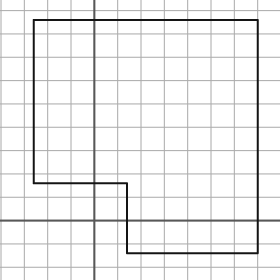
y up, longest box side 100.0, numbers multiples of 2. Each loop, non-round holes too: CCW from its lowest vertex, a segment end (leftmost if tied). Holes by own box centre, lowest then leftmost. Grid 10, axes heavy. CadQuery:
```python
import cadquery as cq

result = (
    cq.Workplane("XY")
    .moveTo(14.0, -14.0)
    .lineTo(70.0, -14.0)
    .lineTo(70.0, 86.0)
    .lineTo(-26.0, 86.0)
    .lineTo(-26.0, 16.0)
    .lineTo(14.0, 16.0)
    .close()
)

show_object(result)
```